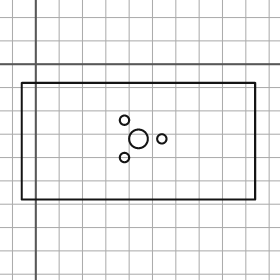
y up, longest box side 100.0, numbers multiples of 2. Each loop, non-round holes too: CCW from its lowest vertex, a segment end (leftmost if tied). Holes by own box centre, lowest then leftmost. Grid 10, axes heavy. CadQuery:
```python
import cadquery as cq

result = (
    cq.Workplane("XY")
    .moveTo(-6.0, -58.0)
    .lineTo(94.0, -58.0)
    .lineTo(94.0, -8.0)
    .lineTo(-6.0, -8.0)
    .close()
    .moveTo(38.0, -40.0)
    .circle(2.0)
    .moveTo(44.0, -32.0)
    .circle(4.0)
    .moveTo(54.0, -32.0)
    .circle(2.0)
    .moveTo(38.0, -24.0)
    .circle(2.0)
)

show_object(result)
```